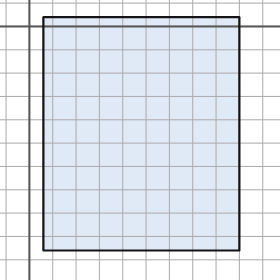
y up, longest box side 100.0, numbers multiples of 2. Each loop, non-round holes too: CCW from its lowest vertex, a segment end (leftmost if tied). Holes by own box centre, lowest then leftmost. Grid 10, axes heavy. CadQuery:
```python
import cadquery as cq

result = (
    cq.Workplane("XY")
    .moveTo(6.0, -96.0)
    .lineTo(90.0, -96.0)
    .lineTo(90.0, 4.0)
    .lineTo(6.0, 4.0)
    .close()
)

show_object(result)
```